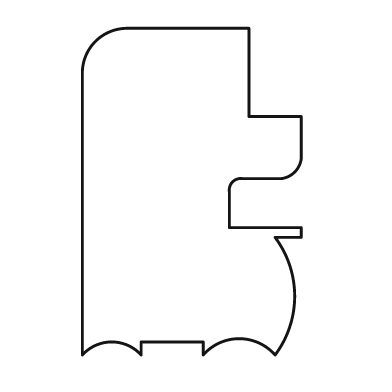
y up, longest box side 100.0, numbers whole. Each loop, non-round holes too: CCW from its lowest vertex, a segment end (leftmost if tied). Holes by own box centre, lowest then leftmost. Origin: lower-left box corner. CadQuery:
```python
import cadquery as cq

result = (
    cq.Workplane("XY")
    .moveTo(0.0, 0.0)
    .threePointArc((9.0, 4.0), (18.0, 0.0))
    .lineTo(18.0, 4.0)
    .lineTo(37.0, 4.0)
    .lineTo(37.0, 0.0)
    .threePointArc((48.0, 5.0), (59.0, 0.0))
    .threePointArc((65.0, 18.0), (59.0, 36.0))
    .lineTo(67.0, 36.0)
    .lineTo(67.0, 39.0)
    .lineTo(45.0, 39.0)
    .lineTo(45.0, 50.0)
    .threePointArc((46.0, 53.0), (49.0, 54.0))
    .lineTo(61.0, 54.0)
    .threePointArc((65.0, 56.0), (67.0, 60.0))
    .lineTo(67.0, 73.0)
    .lineTo(51.0, 73.0)
    .lineTo(51.0, 100.0)
    .lineTo(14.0, 100.0)
    .threePointArc((4.0, 96.0), (0.0, 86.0))
    .close()
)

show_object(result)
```